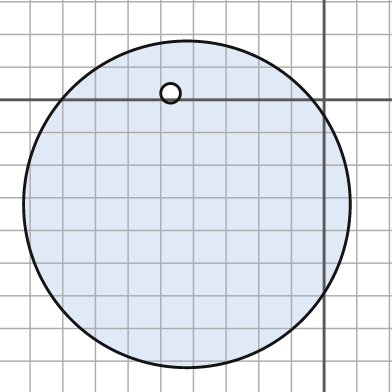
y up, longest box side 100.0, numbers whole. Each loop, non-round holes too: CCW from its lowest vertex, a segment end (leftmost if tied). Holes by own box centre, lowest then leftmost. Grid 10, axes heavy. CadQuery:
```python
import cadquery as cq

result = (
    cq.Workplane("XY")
    .moveTo(-42.0, -32.0)
    .circle(50.0)
    .moveTo(-47.0, 2.0)
    .circle(3.0)
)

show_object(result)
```